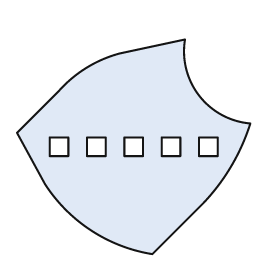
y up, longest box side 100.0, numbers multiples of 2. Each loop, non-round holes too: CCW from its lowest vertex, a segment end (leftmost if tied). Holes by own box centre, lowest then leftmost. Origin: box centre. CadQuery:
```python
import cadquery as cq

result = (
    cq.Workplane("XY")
    .moveTo(8.0, -46.0)
    .lineTo(30.0, -24.0)
    .threePointArc((42.0, -8.0), (50.0, 10.0))
    .threePointArc((28.0, 22.0), (22.0, 46.0))
    .lineTo(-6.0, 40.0)
    .threePointArc((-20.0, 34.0), (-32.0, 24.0))
    .lineTo(-50.0, 6.0)
    .lineTo(-38.0, -16.0)
    .threePointArc((-18.0, -36.0), (8.0, -46.0))
    .close()
    .moveTo(-36.0, -4.0)
    .lineTo(-28.0, -4.0)
    .lineTo(-28.0, 4.0)
    .lineTo(-36.0, 4.0)
    .close()
    .moveTo(-20.0, -4.0)
    .lineTo(-12.0, -4.0)
    .lineTo(-12.0, 4.0)
    .lineTo(-20.0, 4.0)
    .close()
    .moveTo(-4.0, -4.0)
    .lineTo(4.0, -4.0)
    .lineTo(4.0, 4.0)
    .lineTo(-4.0, 4.0)
    .close()
    .moveTo(12.0, -4.0)
    .lineTo(20.0, -4.0)
    .lineTo(20.0, 4.0)
    .lineTo(12.0, 4.0)
    .close()
    .moveTo(28.0, -4.0)
    .lineTo(36.0, -4.0)
    .lineTo(36.0, 4.0)
    .lineTo(28.0, 4.0)
    .close()
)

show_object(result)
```